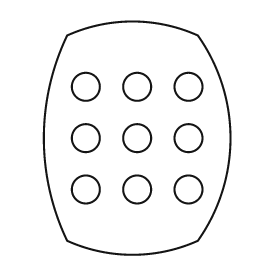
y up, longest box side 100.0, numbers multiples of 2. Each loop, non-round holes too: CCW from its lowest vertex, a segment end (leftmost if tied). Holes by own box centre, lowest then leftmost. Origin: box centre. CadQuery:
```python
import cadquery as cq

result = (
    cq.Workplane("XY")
    .moveTo(-30.0, -44.0)
    .threePointArc((-2.0, -50.0), (26.0, -44.0))
    .threePointArc((40.0, 0.0), (26.0, 44.0))
    .threePointArc((-2.0, 50.0), (-30.0, 44.0))
    .threePointArc((-40.0, 0.0), (-30.0, -44.0))
    .close()
    .moveTo(-22.0, -22.0)
    .circle(6.0)
    .moveTo(0.0, -22.0)
    .circle(6.0)
    .moveTo(22.0, -22.0)
    .circle(6.0)
    .moveTo(-22.0, 0.0)
    .circle(6.0)
    .moveTo(0.0, 0.0)
    .circle(6.0)
    .moveTo(22.0, 0.0)
    .circle(6.0)
    .moveTo(-22.0, 22.0)
    .circle(6.0)
    .moveTo(0.0, 22.0)
    .circle(6.0)
    .moveTo(22.0, 22.0)
    .circle(6.0)
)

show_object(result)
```